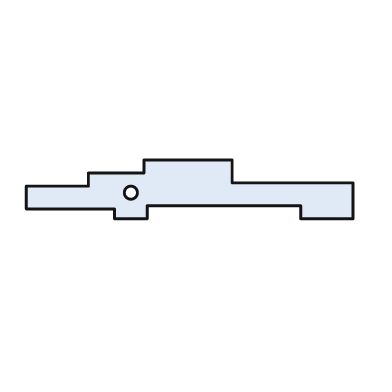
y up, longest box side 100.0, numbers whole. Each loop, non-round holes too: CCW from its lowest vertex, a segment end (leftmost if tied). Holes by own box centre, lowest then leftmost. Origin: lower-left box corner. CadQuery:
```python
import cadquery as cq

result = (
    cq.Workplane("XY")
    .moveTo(27.0, 0.0)
    .lineTo(37.0, 0.0)
    .lineTo(37.0, 4.0)
    .lineTo(84.0, 4.0)
    .lineTo(84.0, 0.0)
    .lineTo(100.0, 0.0)
    .lineTo(100.0, 11.0)
    .lineTo(63.0, 11.0)
    .lineTo(63.0, 18.0)
    .lineTo(36.0, 18.0)
    .lineTo(36.0, 14.0)
    .lineTo(19.0, 14.0)
    .lineTo(19.0, 10.0)
    .lineTo(0.0, 10.0)
    .lineTo(0.0, 3.0)
    .lineTo(27.0, 3.0)
    .close()
    .moveTo(32.0, 8.0)
    .circle(2.0)
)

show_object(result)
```